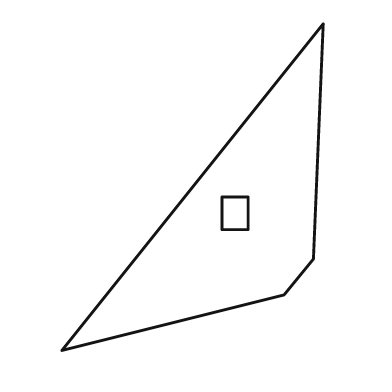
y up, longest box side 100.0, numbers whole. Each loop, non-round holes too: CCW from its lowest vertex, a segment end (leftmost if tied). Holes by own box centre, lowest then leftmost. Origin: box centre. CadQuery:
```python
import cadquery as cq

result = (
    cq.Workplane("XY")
    .moveTo(-40.0, -50.0)
    .lineTo(28.0, -33.0)
    .lineTo(37.0, -22.0)
    .lineTo(40.0, 50.0)
    .close()
    .moveTo(9.0, -13.0)
    .lineTo(17.0, -13.0)
    .lineTo(17.0, -3.0)
    .lineTo(9.0, -3.0)
    .close()
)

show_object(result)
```